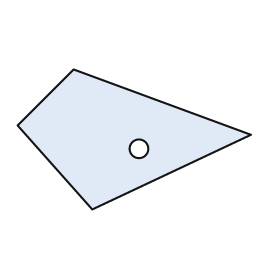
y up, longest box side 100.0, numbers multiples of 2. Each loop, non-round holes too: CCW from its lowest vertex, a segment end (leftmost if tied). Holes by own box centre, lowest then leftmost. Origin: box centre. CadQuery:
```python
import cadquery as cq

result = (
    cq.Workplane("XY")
    .moveTo(-18.0, -30.0)
    .lineTo(50.0, 2.0)
    .lineTo(-26.0, 30.0)
    .lineTo(-50.0, 6.0)
    .close()
    .moveTo(2.0, -4.0)
    .circle(4.0)
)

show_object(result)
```